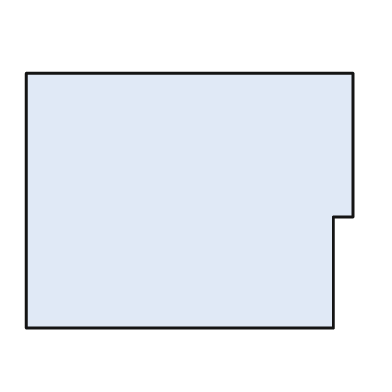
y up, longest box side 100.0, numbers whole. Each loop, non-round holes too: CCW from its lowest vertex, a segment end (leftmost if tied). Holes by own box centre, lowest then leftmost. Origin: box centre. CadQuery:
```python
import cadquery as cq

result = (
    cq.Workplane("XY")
    .moveTo(-50.0, -39.0)
    .lineTo(44.0, -39.0)
    .lineTo(44.0, -5.0)
    .lineTo(50.0, -5.0)
    .lineTo(50.0, 39.0)
    .lineTo(-50.0, 39.0)
    .close()
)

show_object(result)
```